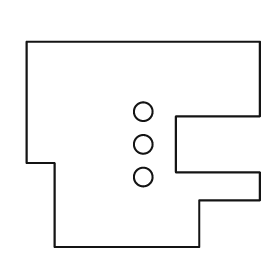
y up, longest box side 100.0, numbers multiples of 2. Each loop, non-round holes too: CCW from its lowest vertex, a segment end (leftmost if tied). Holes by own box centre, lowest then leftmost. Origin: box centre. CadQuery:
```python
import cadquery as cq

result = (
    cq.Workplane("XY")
    .moveTo(-38.0, -44.0)
    .lineTo(24.0, -44.0)
    .lineTo(24.0, -24.0)
    .lineTo(50.0, -24.0)
    .lineTo(50.0, -12.0)
    .lineTo(14.0, -12.0)
    .lineTo(14.0, 12.0)
    .lineTo(50.0, 12.0)
    .lineTo(50.0, 44.0)
    .lineTo(-50.0, 44.0)
    .lineTo(-50.0, -8.0)
    .lineTo(-38.0, -8.0)
    .close()
    .moveTo(0.0, -14.0)
    .circle(4.0)
    .moveTo(0.0, 0.0)
    .circle(4.0)
    .moveTo(0.0, 14.0)
    .circle(4.0)
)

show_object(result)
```